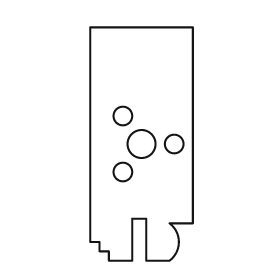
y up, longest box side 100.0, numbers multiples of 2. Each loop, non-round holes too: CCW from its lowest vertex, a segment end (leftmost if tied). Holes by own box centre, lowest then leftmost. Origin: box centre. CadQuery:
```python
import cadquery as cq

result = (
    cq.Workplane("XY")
    .moveTo(-14.0, -50.0)
    .lineTo(-4.0, -50.0)
    .lineTo(-4.0, -32.0)
    .lineTo(2.0, -32.0)
    .lineTo(2.0, -50.0)
    .lineTo(12.0, -50.0)
    .threePointArc((16.0, -42.0), (12.0, -34.0))
    .lineTo(22.0, -34.0)
    .lineTo(22.0, 50.0)
    .lineTo(-22.0, 50.0)
    .lineTo(-22.0, -42.0)
    .lineTo(-18.0, -42.0)
    .lineTo(-18.0, -46.0)
    .lineTo(-14.0, -46.0)
    .close()
    .moveTo(-8.0, -12.0)
    .circle(4.0)
    .moveTo(0.0, 0.0)
    .circle(6.0)
    .moveTo(14.0, 0.0)
    .circle(4.0)
    .moveTo(-8.0, 12.0)
    .circle(4.0)
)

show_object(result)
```